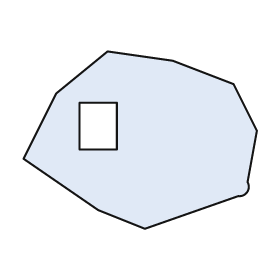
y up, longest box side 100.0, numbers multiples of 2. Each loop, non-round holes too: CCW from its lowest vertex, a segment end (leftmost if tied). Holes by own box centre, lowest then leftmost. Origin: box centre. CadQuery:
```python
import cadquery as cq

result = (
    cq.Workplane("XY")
    .moveTo(2.0, -38.0)
    .lineTo(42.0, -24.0)
    .threePointArc((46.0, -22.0), (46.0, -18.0))
    .lineTo(50.0, 4.0)
    .lineTo(40.0, 24.0)
    .lineTo(14.0, 34.0)
    .lineTo(-14.0, 38.0)
    .lineTo(-36.0, 20.0)
    .lineTo(-50.0, -8.0)
    .lineTo(-18.0, -30.0)
    .close()
    .moveTo(-26.0, -4.0)
    .lineTo(-10.0, -4.0)
    .lineTo(-10.0, 16.0)
    .lineTo(-26.0, 16.0)
    .close()
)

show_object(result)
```